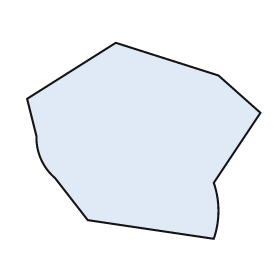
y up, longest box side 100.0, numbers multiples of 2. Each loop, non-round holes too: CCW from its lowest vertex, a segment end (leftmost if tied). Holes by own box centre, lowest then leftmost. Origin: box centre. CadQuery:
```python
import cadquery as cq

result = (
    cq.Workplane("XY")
    .moveTo(30.0, -42.0)
    .threePointArc((32.0, -30.0), (30.0, -18.0))
    .lineTo(50.0, 12.0)
    .lineTo(32.0, 28.0)
    .lineTo(-12.0, 42.0)
    .lineTo(-50.0, 18.0)
    .lineTo(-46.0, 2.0)
    .threePointArc((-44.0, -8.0), (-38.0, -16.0))
    .lineTo(-24.0, -34.0)
    .close()
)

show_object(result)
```